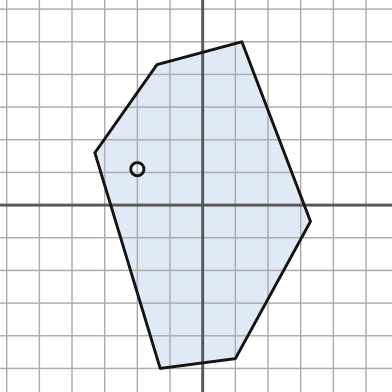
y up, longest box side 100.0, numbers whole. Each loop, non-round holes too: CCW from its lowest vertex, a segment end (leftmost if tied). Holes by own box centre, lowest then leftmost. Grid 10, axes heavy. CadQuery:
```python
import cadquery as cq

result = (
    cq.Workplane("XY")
    .moveTo(-13.0, -50.0)
    .lineTo(10.0, -47.0)
    .lineTo(33.0, -5.0)
    .lineTo(12.0, 50.0)
    .lineTo(-14.0, 43.0)
    .lineTo(-33.0, 16.0)
    .close()
    .moveTo(-20.0, 11.0)
    .circle(2.0)
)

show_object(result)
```